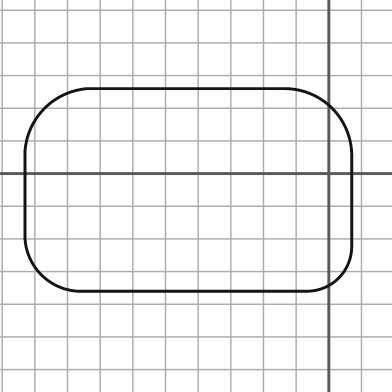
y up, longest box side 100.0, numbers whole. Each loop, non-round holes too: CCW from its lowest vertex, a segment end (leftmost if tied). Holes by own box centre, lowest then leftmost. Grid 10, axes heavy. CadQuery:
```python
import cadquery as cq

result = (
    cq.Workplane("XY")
    .moveTo(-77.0, -36.0)
    .lineTo(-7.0, -36.0)
    .threePointArc((3.0, -32.0), (7.0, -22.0))
    .lineTo(7.0, 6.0)
    .threePointArc((1.0, 20.0), (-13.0, 26.0))
    .lineTo(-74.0, 26.0)
    .threePointArc((-87.0, 20.0), (-93.0, 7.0))
    .lineTo(-93.0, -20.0)
    .threePointArc((-88.0, -31.0), (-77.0, -36.0))
    .close()
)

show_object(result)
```